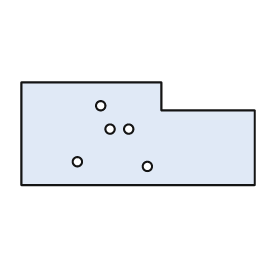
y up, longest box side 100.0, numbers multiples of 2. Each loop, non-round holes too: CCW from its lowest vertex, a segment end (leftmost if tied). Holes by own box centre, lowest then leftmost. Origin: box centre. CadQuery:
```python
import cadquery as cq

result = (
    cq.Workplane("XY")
    .moveTo(-50.0, -22.0)
    .lineTo(50.0, -22.0)
    .lineTo(50.0, 10.0)
    .lineTo(10.0, 10.0)
    .lineTo(10.0, 22.0)
    .lineTo(-50.0, 22.0)
    .close()
    .moveTo(4.0, -14.0)
    .circle(2.0)
    .moveTo(-26.0, -12.0)
    .circle(2.0)
    .moveTo(-12.0, 2.0)
    .circle(2.0)
    .moveTo(-4.0, 2.0)
    .circle(2.0)
    .moveTo(-16.0, 12.0)
    .circle(2.0)
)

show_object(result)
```